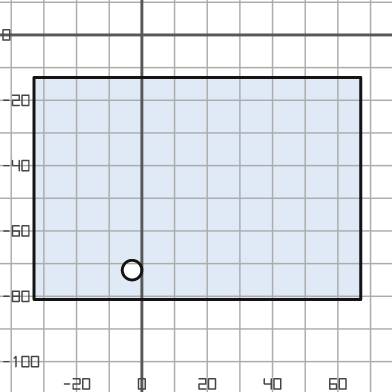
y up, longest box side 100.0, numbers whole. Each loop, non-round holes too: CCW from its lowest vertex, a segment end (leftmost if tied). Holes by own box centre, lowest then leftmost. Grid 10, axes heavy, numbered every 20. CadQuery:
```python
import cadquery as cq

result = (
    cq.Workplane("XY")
    .moveTo(-33.0, -81.0)
    .lineTo(67.0, -81.0)
    .lineTo(67.0, -13.0)
    .lineTo(-33.0, -13.0)
    .close()
    .moveTo(-3.0, -72.0)
    .circle(3.0)
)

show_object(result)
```